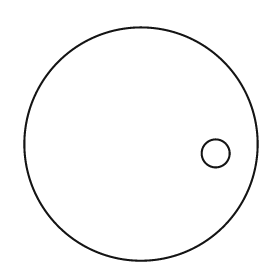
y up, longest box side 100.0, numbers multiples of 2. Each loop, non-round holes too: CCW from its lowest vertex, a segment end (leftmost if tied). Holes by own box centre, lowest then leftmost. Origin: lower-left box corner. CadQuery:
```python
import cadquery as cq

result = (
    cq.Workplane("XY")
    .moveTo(50.0, 50.0)
    .circle(50.0)
    .moveTo(82.0, 46.0)
    .circle(6.0)
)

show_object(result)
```